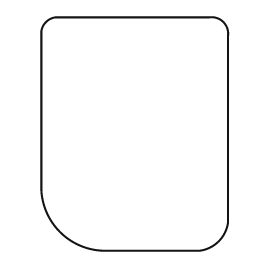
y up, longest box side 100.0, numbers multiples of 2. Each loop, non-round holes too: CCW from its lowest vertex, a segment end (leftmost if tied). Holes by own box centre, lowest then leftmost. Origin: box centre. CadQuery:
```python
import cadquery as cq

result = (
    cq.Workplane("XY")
    .moveTo(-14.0, -50.0)
    .lineTo(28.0, -50.0)
    .threePointArc((36.0, -46.0), (40.0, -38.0))
    .lineTo(40.0, 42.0)
    .threePointArc((38.0, 48.0), (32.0, 50.0))
    .lineTo(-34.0, 50.0)
    .threePointArc((-38.0, 48.0), (-40.0, 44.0))
    .lineTo(-40.0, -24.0)
    .threePointArc((-32.0, -42.0), (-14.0, -50.0))
    .close()
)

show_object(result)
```